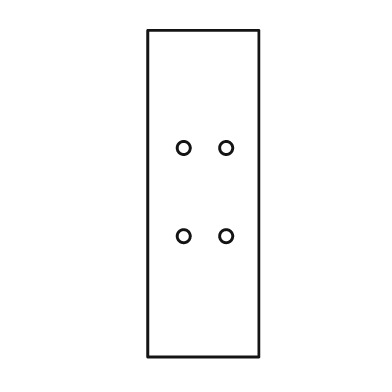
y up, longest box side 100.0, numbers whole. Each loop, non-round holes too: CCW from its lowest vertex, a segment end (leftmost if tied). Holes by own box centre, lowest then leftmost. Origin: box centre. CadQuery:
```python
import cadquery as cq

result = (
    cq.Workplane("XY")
    .moveTo(-17.0, -50.0)
    .lineTo(17.0, -50.0)
    .lineTo(17.0, 50.0)
    .lineTo(-17.0, 50.0)
    .close()
    .moveTo(-6.0, -13.0)
    .circle(2.0)
    .moveTo(7.0, -13.0)
    .circle(2.0)
    .moveTo(-6.0, 14.0)
    .circle(2.0)
    .moveTo(7.0, 14.0)
    .circle(2.0)
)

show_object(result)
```